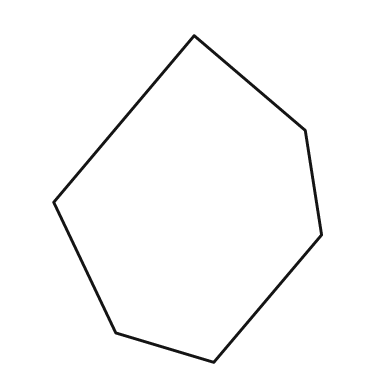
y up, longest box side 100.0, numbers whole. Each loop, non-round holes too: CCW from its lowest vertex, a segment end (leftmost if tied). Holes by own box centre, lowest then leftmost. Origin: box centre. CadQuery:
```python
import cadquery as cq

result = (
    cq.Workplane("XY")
    .moveTo(8.0, -50.0)
    .lineTo(41.0, -11.0)
    .lineTo(36.0, 21.0)
    .lineTo(2.0, 50.0)
    .lineTo(-41.0, -1.0)
    .lineTo(-22.0, -41.0)
    .close()
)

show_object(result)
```